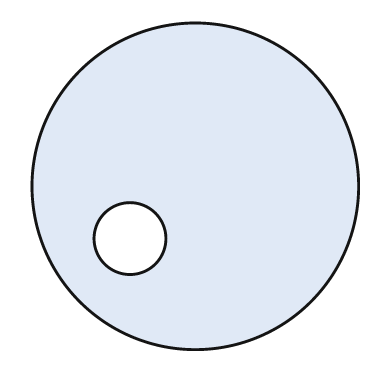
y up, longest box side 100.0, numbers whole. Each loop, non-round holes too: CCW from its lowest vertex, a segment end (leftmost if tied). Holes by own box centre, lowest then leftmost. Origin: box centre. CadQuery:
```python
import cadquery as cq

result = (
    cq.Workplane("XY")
    .moveTo(0.0, 0.0)
    .circle(50.0)
    .moveTo(-20.0, -16.0)
    .circle(11.0)
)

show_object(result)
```